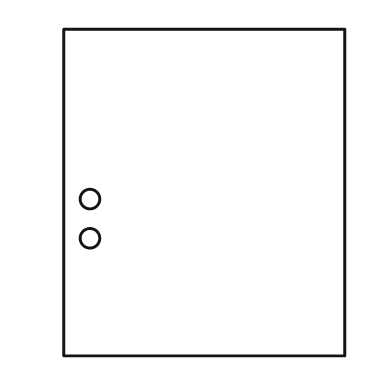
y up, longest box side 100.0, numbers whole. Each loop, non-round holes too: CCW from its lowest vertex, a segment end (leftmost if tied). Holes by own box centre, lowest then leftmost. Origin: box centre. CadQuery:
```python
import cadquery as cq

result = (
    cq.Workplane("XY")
    .moveTo(-43.0, -50.0)
    .lineTo(43.0, -50.0)
    .lineTo(43.0, 50.0)
    .lineTo(-43.0, 50.0)
    .close()
    .moveTo(-35.0, -14.0)
    .circle(3.0)
    .moveTo(-35.0, -2.0)
    .circle(3.0)
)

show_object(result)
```